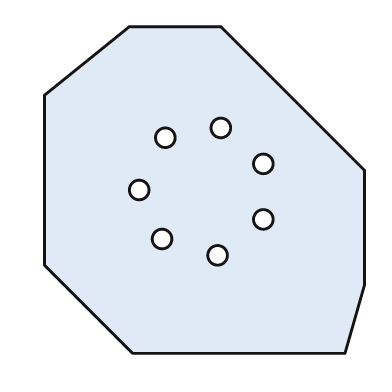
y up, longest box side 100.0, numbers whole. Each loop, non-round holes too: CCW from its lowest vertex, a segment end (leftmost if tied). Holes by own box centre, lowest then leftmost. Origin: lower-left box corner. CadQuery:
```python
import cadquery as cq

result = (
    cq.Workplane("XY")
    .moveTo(27.0, 0.0)
    .lineTo(92.0, 0.0)
    .lineTo(98.0, 21.0)
    .lineTo(98.0, 56.0)
    .lineTo(54.0, 100.0)
    .lineTo(26.0, 100.0)
    .lineTo(0.0, 79.0)
    .lineTo(0.0, 27.0)
    .close()
    .moveTo(53.0, 30.0)
    .circle(3.0)
    .moveTo(36.0, 35.0)
    .circle(3.0)
    .moveTo(67.0, 41.0)
    .circle(3.0)
    .moveTo(29.0, 50.0)
    .circle(3.0)
    .moveTo(67.0, 58.0)
    .circle(3.0)
    .moveTo(37.0, 66.0)
    .circle(3.0)
    .moveTo(54.0, 69.0)
    .circle(3.0)
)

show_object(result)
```